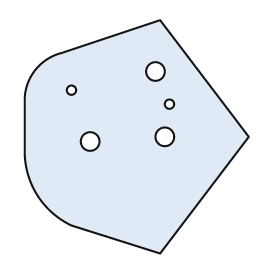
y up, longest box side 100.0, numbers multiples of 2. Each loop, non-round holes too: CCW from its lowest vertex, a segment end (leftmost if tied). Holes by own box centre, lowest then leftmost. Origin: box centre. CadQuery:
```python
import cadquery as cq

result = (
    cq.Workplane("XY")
    .moveTo(10.0, -50.0)
    .lineTo(48.0, 0.0)
    .lineTo(10.0, 50.0)
    .lineTo(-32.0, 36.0)
    .threePointArc((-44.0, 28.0), (-48.0, 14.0))
    .lineTo(-48.0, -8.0)
    .threePointArc((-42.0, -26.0), (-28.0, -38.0))
    .close()
    .moveTo(-20.0, -2.0)
    .circle(4.0)
    .moveTo(12.0, 0.0)
    .circle(4.0)
    .moveTo(14.0, 14.0)
    .circle(2.0)
    .moveTo(-28.0, 20.0)
    .circle(2.0)
    .moveTo(8.0, 28.0)
    .circle(4.0)
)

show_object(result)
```